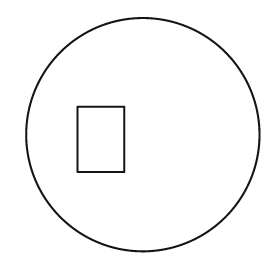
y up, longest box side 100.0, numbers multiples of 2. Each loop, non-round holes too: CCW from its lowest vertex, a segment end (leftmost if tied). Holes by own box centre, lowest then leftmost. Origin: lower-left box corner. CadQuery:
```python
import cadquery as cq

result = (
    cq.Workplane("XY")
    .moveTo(50.0, 50.0)
    .circle(50.0)
    .moveTo(22.0, 34.0)
    .lineTo(42.0, 34.0)
    .lineTo(42.0, 62.0)
    .lineTo(22.0, 62.0)
    .close()
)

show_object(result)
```